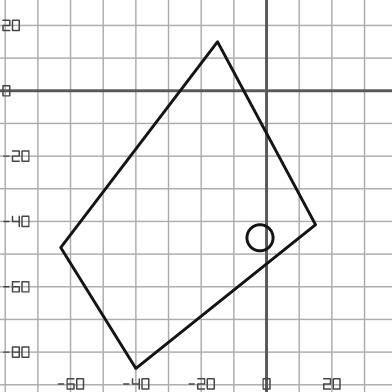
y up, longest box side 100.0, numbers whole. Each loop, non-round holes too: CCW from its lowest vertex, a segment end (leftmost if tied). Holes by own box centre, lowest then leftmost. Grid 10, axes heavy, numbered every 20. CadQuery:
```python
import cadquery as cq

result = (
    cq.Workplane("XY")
    .moveTo(-40.0, -85.0)
    .lineTo(15.0, -41.0)
    .lineTo(-15.0, 15.0)
    .lineTo(-63.0, -48.0)
    .close()
    .moveTo(-2.0, -45.0)
    .circle(4.0)
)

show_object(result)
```